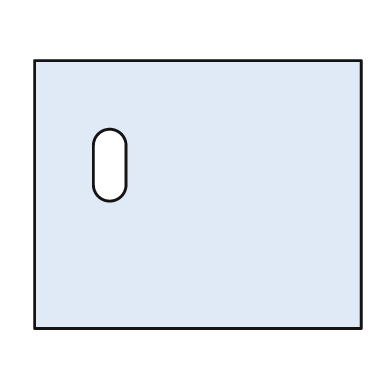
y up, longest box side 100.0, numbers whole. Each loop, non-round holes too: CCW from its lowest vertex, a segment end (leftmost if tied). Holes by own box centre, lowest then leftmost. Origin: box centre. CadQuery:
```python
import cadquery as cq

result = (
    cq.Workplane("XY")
    .moveTo(-50.0, -41.0)
    .lineTo(50.0, -41.0)
    .lineTo(50.0, 41.0)
    .lineTo(-50.0, 41.0)
    .close()
    .moveTo(-32.0, 3.0)
    .threePointArc((-27.0, -2.0), (-22.0, 3.0))
    .lineTo(-22.0, 15.0)
    .threePointArc((-27.0, 20.0), (-32.0, 15.0))
    .close()
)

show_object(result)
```